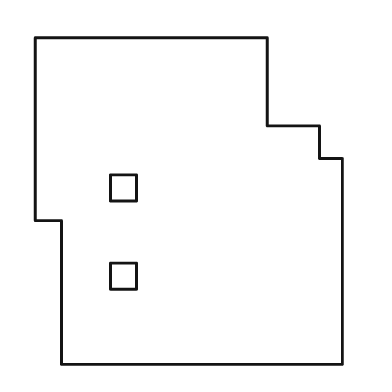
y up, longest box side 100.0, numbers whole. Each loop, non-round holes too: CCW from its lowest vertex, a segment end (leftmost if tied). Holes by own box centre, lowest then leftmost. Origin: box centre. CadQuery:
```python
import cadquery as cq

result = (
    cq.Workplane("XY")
    .moveTo(-39.0, -50.0)
    .lineTo(47.0, -50.0)
    .lineTo(47.0, 13.0)
    .lineTo(40.0, 13.0)
    .lineTo(40.0, 23.0)
    .lineTo(24.0, 23.0)
    .lineTo(24.0, 50.0)
    .lineTo(-47.0, 50.0)
    .lineTo(-47.0, -6.0)
    .lineTo(-39.0, -6.0)
    .close()
    .moveTo(-24.0, -27.0)
    .lineTo(-16.0, -27.0)
    .lineTo(-16.0, -19.0)
    .lineTo(-24.0, -19.0)
    .close()
    .moveTo(-24.0, 0.0)
    .lineTo(-16.0, 0.0)
    .lineTo(-16.0, 8.0)
    .lineTo(-24.0, 8.0)
    .close()
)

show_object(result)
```